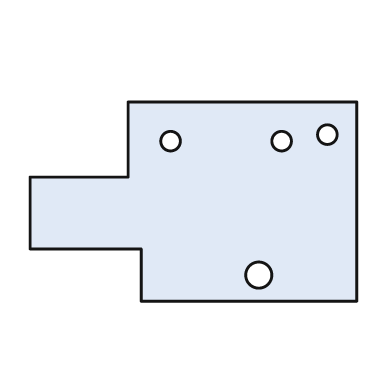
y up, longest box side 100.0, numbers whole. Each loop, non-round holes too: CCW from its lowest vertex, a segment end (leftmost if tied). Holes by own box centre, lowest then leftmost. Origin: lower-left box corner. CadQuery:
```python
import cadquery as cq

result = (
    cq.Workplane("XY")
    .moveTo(34.0, 0.0)
    .lineTo(100.0, 0.0)
    .lineTo(100.0, 61.0)
    .lineTo(30.0, 61.0)
    .lineTo(30.0, 38.0)
    .lineTo(0.0, 38.0)
    .lineTo(0.0, 16.0)
    .lineTo(34.0, 16.0)
    .close()
    .moveTo(70.0, 8.0)
    .circle(4.0)
    .moveTo(43.0, 49.0)
    .circle(3.0)
    .moveTo(77.0, 49.0)
    .circle(3.0)
    .moveTo(91.0, 51.0)
    .circle(3.0)
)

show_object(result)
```